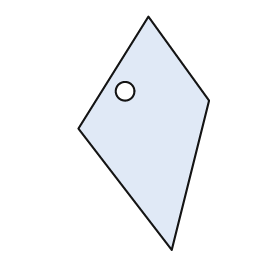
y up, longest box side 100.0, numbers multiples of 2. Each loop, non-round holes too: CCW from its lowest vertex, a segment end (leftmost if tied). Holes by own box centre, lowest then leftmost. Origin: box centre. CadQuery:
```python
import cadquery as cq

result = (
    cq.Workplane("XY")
    .moveTo(12.0, -50.0)
    .lineTo(28.0, 14.0)
    .lineTo(2.0, 50.0)
    .lineTo(-28.0, 2.0)
    .close()
    .moveTo(-8.0, 18.0)
    .circle(4.0)
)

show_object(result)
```